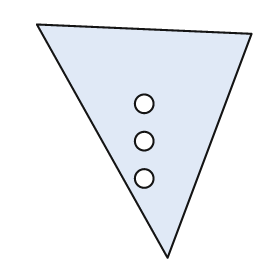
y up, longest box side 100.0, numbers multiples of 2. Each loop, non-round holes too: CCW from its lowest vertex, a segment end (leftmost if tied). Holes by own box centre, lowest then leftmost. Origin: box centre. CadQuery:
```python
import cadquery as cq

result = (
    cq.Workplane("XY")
    .moveTo(10.0, -50.0)
    .lineTo(46.0, 46.0)
    .lineTo(-46.0, 50.0)
    .close()
    .moveTo(0.0, -16.0)
    .circle(4.0)
    .moveTo(0.0, 0.0)
    .circle(4.0)
    .moveTo(0.0, 16.0)
    .circle(4.0)
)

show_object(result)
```